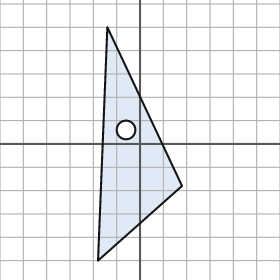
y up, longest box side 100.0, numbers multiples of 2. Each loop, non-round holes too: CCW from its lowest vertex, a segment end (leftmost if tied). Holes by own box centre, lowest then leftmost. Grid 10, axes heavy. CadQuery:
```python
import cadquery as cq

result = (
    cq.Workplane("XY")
    .moveTo(-18.0, -50.0)
    .lineTo(18.0, -18.0)
    .lineTo(-14.0, 50.0)
    .close()
    .moveTo(-6.0, 6.0)
    .circle(4.0)
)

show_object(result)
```